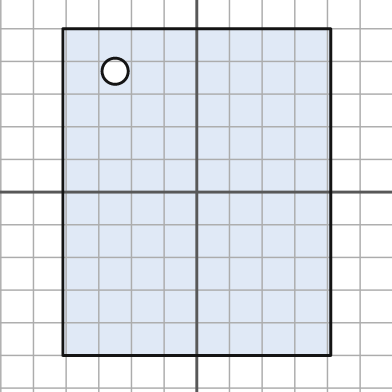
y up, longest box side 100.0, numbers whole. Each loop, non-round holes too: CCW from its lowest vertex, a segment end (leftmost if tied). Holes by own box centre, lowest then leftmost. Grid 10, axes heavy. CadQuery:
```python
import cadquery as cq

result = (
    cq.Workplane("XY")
    .moveTo(-41.0, -50.0)
    .lineTo(41.0, -50.0)
    .lineTo(41.0, 50.0)
    .lineTo(-41.0, 50.0)
    .close()
    .moveTo(-25.0, 37.0)
    .circle(4.0)
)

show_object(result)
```